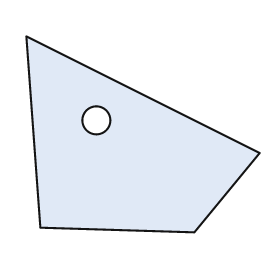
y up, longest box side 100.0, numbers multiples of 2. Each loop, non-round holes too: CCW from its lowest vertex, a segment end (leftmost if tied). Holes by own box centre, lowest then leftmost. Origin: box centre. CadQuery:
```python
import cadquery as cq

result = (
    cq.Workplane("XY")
    .moveTo(22.0, -42.0)
    .lineTo(50.0, -8.0)
    .lineTo(-50.0, 42.0)
    .lineTo(-44.0, -40.0)
    .close()
    .moveTo(-20.0, 6.0)
    .circle(6.0)
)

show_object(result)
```